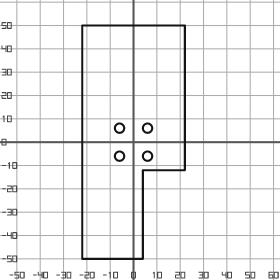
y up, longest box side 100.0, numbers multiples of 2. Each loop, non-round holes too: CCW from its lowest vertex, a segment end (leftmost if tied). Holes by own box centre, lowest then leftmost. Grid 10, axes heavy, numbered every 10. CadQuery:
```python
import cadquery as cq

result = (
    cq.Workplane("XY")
    .moveTo(-22.0, -50.0)
    .lineTo(4.0, -50.0)
    .lineTo(4.0, -12.0)
    .lineTo(22.0, -12.0)
    .lineTo(22.0, 50.0)
    .lineTo(-22.0, 50.0)
    .close()
    .moveTo(-6.0, -6.0)
    .circle(2.0)
    .moveTo(6.0, -6.0)
    .circle(2.0)
    .moveTo(-6.0, 6.0)
    .circle(2.0)
    .moveTo(6.0, 6.0)
    .circle(2.0)
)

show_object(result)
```